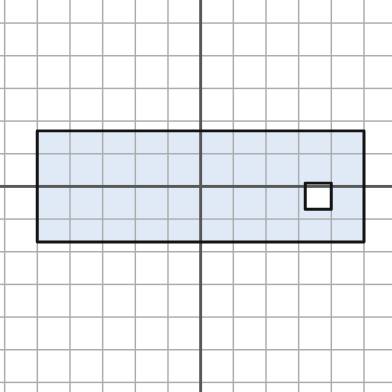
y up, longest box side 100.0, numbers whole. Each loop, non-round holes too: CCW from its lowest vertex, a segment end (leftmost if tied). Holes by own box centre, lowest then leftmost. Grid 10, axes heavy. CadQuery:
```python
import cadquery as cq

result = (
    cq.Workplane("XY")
    .moveTo(-50.0, -17.0)
    .lineTo(50.0, -17.0)
    .lineTo(50.0, 17.0)
    .lineTo(-50.0, 17.0)
    .close()
    .moveTo(32.0, -7.0)
    .lineTo(40.0, -7.0)
    .lineTo(40.0, 1.0)
    .lineTo(32.0, 1.0)
    .close()
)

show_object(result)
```